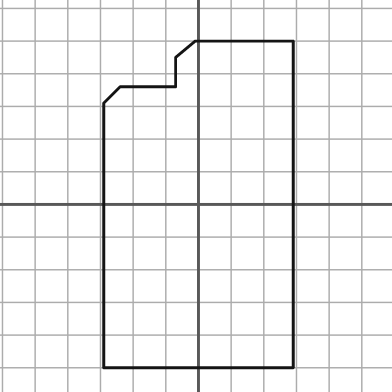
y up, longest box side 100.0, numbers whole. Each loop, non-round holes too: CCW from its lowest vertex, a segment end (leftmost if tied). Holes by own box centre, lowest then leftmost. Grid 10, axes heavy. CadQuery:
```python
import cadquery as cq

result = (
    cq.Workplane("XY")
    .moveTo(-29.0, -50.0)
    .lineTo(29.0, -50.0)
    .lineTo(29.0, 50.0)
    .lineTo(-1.0, 50.0)
    .lineTo(-7.0, 45.0)
    .lineTo(-7.0, 36.0)
    .lineTo(-24.0, 36.0)
    .lineTo(-29.0, 31.0)
    .close()
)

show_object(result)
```